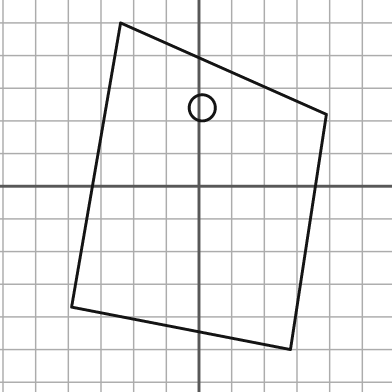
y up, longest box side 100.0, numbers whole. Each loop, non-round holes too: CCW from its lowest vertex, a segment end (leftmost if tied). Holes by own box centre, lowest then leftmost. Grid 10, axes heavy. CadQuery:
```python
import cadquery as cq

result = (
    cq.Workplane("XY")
    .moveTo(28.0, -50.0)
    .lineTo(39.0, 22.0)
    .lineTo(-24.0, 50.0)
    .lineTo(-39.0, -37.0)
    .close()
    .moveTo(1.0, 24.0)
    .circle(4.0)
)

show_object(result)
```